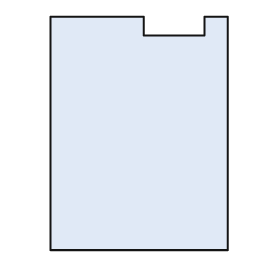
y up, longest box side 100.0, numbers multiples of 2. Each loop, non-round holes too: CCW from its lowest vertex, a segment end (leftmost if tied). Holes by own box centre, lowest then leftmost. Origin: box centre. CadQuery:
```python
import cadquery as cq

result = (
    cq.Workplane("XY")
    .moveTo(-38.0, -50.0)
    .lineTo(38.0, -50.0)
    .lineTo(38.0, 50.0)
    .lineTo(28.0, 50.0)
    .lineTo(28.0, 42.0)
    .lineTo(2.0, 42.0)
    .lineTo(2.0, 50.0)
    .lineTo(-38.0, 50.0)
    .close()
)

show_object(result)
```